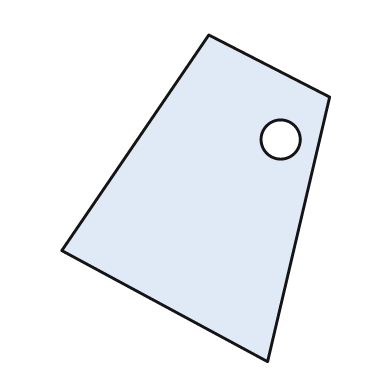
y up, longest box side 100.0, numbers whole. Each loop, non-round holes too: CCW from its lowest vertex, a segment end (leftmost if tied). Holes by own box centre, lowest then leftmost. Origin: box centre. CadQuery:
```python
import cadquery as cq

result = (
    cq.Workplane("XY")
    .moveTo(22.0, -50.0)
    .lineTo(41.0, 31.0)
    .lineTo(4.0, 50.0)
    .lineTo(-41.0, -16.0)
    .close()
    .moveTo(26.0, 18.0)
    .circle(6.0)
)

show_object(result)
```